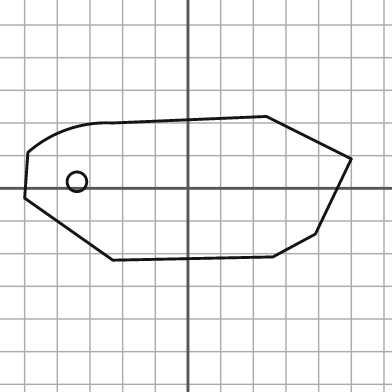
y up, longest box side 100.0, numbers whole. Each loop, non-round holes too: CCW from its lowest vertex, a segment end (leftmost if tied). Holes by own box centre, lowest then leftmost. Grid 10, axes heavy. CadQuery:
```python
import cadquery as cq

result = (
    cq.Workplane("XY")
    .moveTo(-23.0, -22.0)
    .lineTo(26.0, -21.0)
    .lineTo(39.0, -14.0)
    .lineTo(50.0, 9.0)
    .lineTo(24.0, 22.0)
    .lineTo(-23.0, 20.0)
    .threePointArc((-37.0, 18.0), (-49.0, 11.0))
    .lineTo(-50.0, -3.0)
    .close()
    .moveTo(-34.0, 2.0)
    .circle(3.0)
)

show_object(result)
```